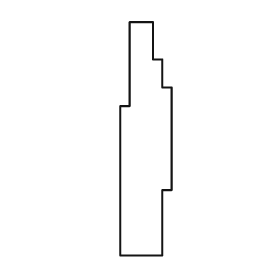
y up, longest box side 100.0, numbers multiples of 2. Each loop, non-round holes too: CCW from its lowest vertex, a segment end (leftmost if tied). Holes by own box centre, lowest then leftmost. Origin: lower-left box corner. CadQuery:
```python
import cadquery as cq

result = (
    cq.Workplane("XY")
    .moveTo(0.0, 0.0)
    .lineTo(18.0, 0.0)
    .lineTo(18.0, 28.0)
    .lineTo(22.0, 28.0)
    .lineTo(22.0, 72.0)
    .lineTo(18.0, 72.0)
    .lineTo(18.0, 84.0)
    .lineTo(14.0, 84.0)
    .lineTo(14.0, 100.0)
    .lineTo(4.0, 100.0)
    .lineTo(4.0, 64.0)
    .lineTo(0.0, 64.0)
    .close()
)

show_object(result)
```